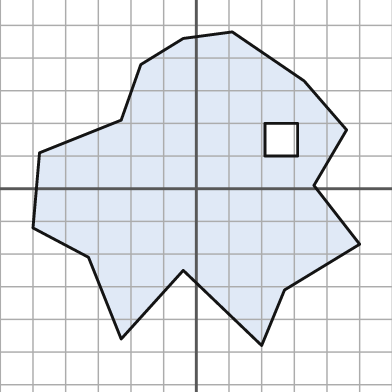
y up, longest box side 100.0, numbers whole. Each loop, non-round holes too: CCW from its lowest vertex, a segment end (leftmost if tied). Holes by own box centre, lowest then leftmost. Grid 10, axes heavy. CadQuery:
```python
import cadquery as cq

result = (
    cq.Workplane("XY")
    .moveTo(20.0, -48.0)
    .lineTo(27.0, -31.0)
    .lineTo(50.0, -17.0)
    .lineTo(36.0, 1.0)
    .lineTo(46.0, 18.0)
    .lineTo(33.0, 33.0)
    .lineTo(11.0, 48.0)
    .lineTo(-4.0, 46.0)
    .lineTo(-17.0, 38.0)
    .lineTo(-23.0, 21.0)
    .lineTo(-48.0, 11.0)
    .lineTo(-50.0, -12.0)
    .lineTo(-33.0, -21.0)
    .lineTo(-23.0, -46.0)
    .lineTo(-4.0, -25.0)
    .close()
    .moveTo(21.0, 10.0)
    .lineTo(31.0, 10.0)
    .lineTo(31.0, 20.0)
    .lineTo(21.0, 20.0)
    .close()
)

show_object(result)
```